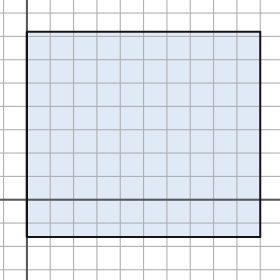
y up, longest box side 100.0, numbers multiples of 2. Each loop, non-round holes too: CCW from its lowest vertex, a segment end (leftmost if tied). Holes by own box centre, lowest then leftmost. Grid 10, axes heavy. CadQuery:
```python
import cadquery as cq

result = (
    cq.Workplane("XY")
    .moveTo(0.0, -16.0)
    .lineTo(100.0, -16.0)
    .lineTo(100.0, 72.0)
    .lineTo(0.0, 72.0)
    .close()
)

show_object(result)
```